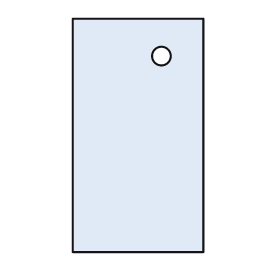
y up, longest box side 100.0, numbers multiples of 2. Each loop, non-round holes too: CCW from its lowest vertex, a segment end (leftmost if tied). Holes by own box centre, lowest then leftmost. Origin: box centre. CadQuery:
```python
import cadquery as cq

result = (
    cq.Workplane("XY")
    .moveTo(-28.0, -50.0)
    .lineTo(28.0, -50.0)
    .lineTo(28.0, 50.0)
    .lineTo(-28.0, 50.0)
    .close()
    .moveTo(10.0, 34.0)
    .circle(4.0)
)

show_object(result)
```